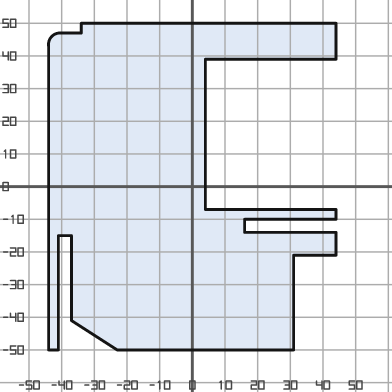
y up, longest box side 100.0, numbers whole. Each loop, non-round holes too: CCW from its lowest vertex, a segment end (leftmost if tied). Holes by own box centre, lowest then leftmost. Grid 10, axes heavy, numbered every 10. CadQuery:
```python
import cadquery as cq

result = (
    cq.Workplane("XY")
    .moveTo(-44.0, -50.0)
    .lineTo(-41.0, -50.0)
    .lineTo(-41.0, -15.0)
    .lineTo(-37.0, -15.0)
    .lineTo(-37.0, -41.0)
    .lineTo(-23.0, -50.0)
    .lineTo(31.0, -50.0)
    .lineTo(31.0, -21.0)
    .lineTo(44.0, -21.0)
    .lineTo(44.0, -14.0)
    .lineTo(16.0, -14.0)
    .lineTo(16.0, -10.0)
    .lineTo(44.0, -10.0)
    .lineTo(44.0, -7.0)
    .lineTo(4.0, -7.0)
    .lineTo(4.0, 39.0)
    .lineTo(44.0, 39.0)
    .lineTo(44.0, 50.0)
    .lineTo(-34.0, 50.0)
    .lineTo(-34.0, 47.0)
    .lineTo(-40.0, 47.0)
    .threePointArc((-43.0, 46.0), (-44.0, 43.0))
    .close()
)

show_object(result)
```